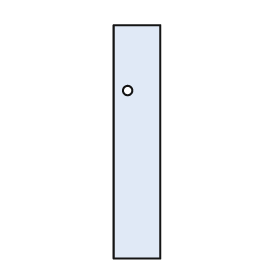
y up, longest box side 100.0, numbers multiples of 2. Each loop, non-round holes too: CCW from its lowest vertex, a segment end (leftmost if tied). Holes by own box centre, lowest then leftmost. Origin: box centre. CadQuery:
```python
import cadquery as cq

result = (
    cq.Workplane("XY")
    .moveTo(-10.0, -50.0)
    .lineTo(10.0, -50.0)
    .lineTo(10.0, 50.0)
    .lineTo(-10.0, 50.0)
    .close()
    .moveTo(-4.0, 22.0)
    .circle(2.0)
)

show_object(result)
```